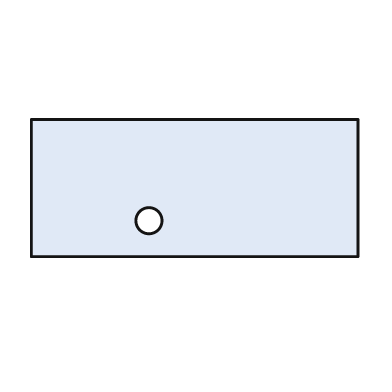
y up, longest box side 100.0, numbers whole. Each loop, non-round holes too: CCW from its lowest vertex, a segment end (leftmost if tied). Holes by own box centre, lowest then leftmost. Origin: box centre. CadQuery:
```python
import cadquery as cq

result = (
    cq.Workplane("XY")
    .moveTo(-50.0, -21.0)
    .lineTo(50.0, -21.0)
    .lineTo(50.0, 21.0)
    .lineTo(-50.0, 21.0)
    .close()
    .moveTo(-14.0, -10.0)
    .circle(4.0)
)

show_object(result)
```